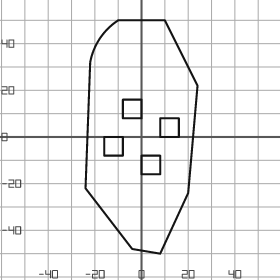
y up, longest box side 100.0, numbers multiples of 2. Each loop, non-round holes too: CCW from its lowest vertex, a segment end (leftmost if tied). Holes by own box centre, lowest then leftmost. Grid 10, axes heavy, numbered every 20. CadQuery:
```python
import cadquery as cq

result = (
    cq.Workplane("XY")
    .moveTo(8.0, -50.0)
    .lineTo(20.0, -24.0)
    .lineTo(24.0, 22.0)
    .lineTo(10.0, 50.0)
    .lineTo(-10.0, 50.0)
    .threePointArc((-18.0, 42.0), (-22.0, 32.0))
    .lineTo(-24.0, -22.0)
    .lineTo(-4.0, -48.0)
    .close()
    .moveTo(0.0, -16.0)
    .lineTo(8.0, -16.0)
    .lineTo(8.0, -8.0)
    .lineTo(0.0, -8.0)
    .close()
    .moveTo(-16.0, -8.0)
    .lineTo(-8.0, -8.0)
    .lineTo(-8.0, 0.0)
    .lineTo(-16.0, 0.0)
    .close()
    .moveTo(8.0, 0.0)
    .lineTo(16.0, 0.0)
    .lineTo(16.0, 8.0)
    .lineTo(8.0, 8.0)
    .close()
    .moveTo(-8.0, 8.0)
    .lineTo(0.0, 8.0)
    .lineTo(0.0, 16.0)
    .lineTo(-8.0, 16.0)
    .close()
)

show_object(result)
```